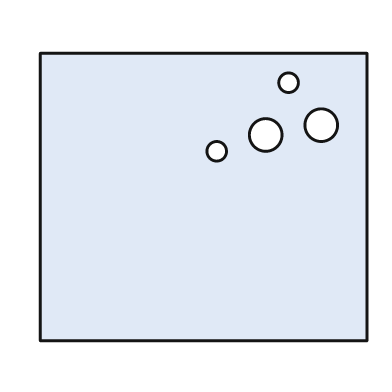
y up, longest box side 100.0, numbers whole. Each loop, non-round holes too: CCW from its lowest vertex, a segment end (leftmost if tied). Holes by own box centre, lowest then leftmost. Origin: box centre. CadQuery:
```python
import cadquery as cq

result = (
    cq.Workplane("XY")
    .moveTo(-50.0, -44.0)
    .lineTo(50.0, -44.0)
    .lineTo(50.0, 44.0)
    .lineTo(-50.0, 44.0)
    .close()
    .moveTo(4.0, 14.0)
    .circle(3.0)
    .moveTo(19.0, 19.0)
    .circle(5.0)
    .moveTo(36.0, 22.0)
    .circle(5.0)
    .moveTo(26.0, 35.0)
    .circle(3.0)
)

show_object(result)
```